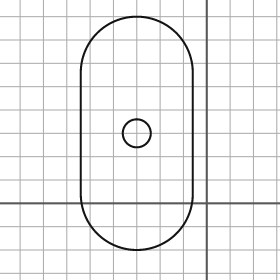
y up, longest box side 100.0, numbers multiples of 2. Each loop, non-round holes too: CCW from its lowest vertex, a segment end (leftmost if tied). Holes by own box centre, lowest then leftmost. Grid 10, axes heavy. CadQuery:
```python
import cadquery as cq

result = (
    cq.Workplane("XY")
    .moveTo(-54.0, 4.0)
    .threePointArc((-30.0, -20.0), (-6.0, 4.0))
    .lineTo(-6.0, 56.0)
    .threePointArc((-30.0, 80.0), (-54.0, 56.0))
    .close()
    .moveTo(-30.0, 30.0)
    .circle(6.0)
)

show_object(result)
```